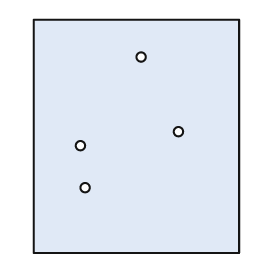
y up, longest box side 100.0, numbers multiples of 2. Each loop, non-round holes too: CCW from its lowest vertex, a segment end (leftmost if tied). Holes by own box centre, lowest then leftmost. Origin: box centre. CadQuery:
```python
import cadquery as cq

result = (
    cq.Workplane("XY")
    .moveTo(-44.0, -50.0)
    .lineTo(44.0, -50.0)
    .lineTo(44.0, 50.0)
    .lineTo(-44.0, 50.0)
    .close()
    .moveTo(-22.0, -22.0)
    .circle(2.0)
    .moveTo(-24.0, -4.0)
    .circle(2.0)
    .moveTo(18.0, 2.0)
    .circle(2.0)
    .moveTo(2.0, 34.0)
    .circle(2.0)
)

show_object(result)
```